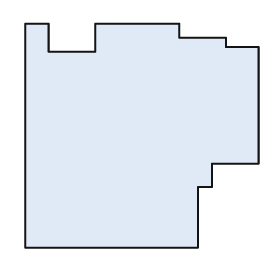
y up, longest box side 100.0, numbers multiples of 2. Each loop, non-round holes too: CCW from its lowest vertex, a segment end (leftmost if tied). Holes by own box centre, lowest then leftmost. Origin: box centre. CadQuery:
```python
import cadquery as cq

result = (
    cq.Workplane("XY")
    .moveTo(-50.0, -48.0)
    .lineTo(24.0, -48.0)
    .lineTo(24.0, -22.0)
    .lineTo(30.0, -22.0)
    .lineTo(30.0, -12.0)
    .lineTo(50.0, -12.0)
    .lineTo(50.0, 38.0)
    .lineTo(36.0, 38.0)
    .lineTo(36.0, 42.0)
    .lineTo(16.0, 42.0)
    .lineTo(16.0, 48.0)
    .lineTo(-20.0, 48.0)
    .lineTo(-20.0, 36.0)
    .lineTo(-40.0, 36.0)
    .lineTo(-40.0, 48.0)
    .lineTo(-50.0, 48.0)
    .close()
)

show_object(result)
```